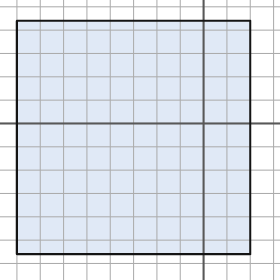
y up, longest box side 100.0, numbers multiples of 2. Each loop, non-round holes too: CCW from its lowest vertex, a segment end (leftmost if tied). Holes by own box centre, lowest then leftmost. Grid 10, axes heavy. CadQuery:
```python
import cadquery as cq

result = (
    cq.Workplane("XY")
    .moveTo(-80.0, -56.0)
    .lineTo(20.0, -56.0)
    .lineTo(20.0, 44.0)
    .lineTo(-80.0, 44.0)
    .close()
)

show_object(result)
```